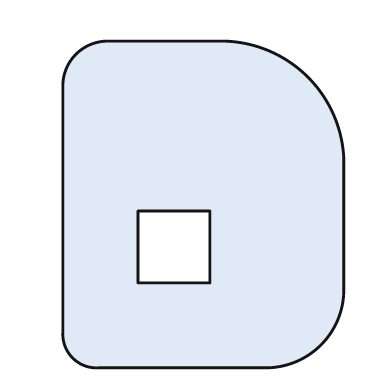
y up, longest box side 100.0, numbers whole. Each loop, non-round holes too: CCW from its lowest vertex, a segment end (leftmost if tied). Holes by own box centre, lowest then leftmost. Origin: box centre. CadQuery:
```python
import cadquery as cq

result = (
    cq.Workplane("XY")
    .moveTo(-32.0, -50.0)
    .lineTo(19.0, -50.0)
    .threePointArc((36.0, -43.0), (43.0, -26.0))
    .lineTo(43.0, 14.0)
    .threePointArc((32.0, 39.0), (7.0, 50.0))
    .lineTo(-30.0, 50.0)
    .threePointArc((-39.0, 46.0), (-43.0, 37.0))
    .lineTo(-43.0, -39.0)
    .threePointArc((-40.0, -47.0), (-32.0, -50.0))
    .close()
    .moveTo(-20.0, -24.0)
    .lineTo(2.0, -24.0)
    .lineTo(2.0, -2.0)
    .lineTo(-20.0, -2.0)
    .close()
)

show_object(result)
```